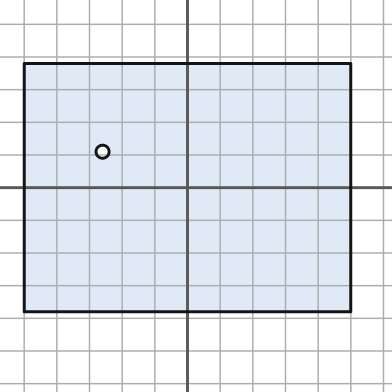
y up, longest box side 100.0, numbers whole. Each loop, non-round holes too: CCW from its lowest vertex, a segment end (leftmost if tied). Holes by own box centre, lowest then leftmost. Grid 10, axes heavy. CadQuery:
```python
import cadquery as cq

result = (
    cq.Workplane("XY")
    .moveTo(-50.0, -38.0)
    .lineTo(50.0, -38.0)
    .lineTo(50.0, 38.0)
    .lineTo(-50.0, 38.0)
    .close()
    .moveTo(-26.0, 11.0)
    .circle(2.0)
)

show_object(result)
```